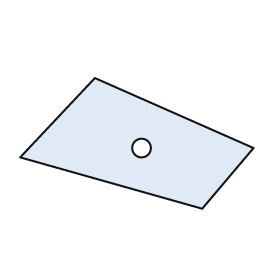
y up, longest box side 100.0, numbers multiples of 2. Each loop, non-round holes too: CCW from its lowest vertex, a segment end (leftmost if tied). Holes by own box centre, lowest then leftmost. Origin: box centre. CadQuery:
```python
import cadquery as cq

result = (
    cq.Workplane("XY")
    .moveTo(28.0, -28.0)
    .lineTo(50.0, -2.0)
    .lineTo(-18.0, 28.0)
    .lineTo(-50.0, -6.0)
    .close()
    .moveTo(2.0, -2.0)
    .circle(4.0)
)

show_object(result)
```